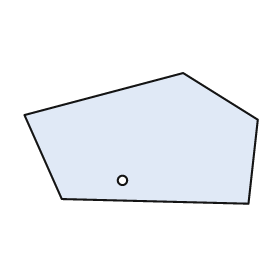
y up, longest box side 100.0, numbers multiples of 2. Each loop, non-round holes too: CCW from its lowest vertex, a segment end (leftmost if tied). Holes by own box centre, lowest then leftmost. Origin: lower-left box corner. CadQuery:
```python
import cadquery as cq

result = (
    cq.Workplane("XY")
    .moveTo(96.0, 0.0)
    .lineTo(100.0, 36.0)
    .lineTo(68.0, 56.0)
    .lineTo(0.0, 38.0)
    .lineTo(16.0, 2.0)
    .close()
    .moveTo(42.0, 10.0)
    .circle(2.0)
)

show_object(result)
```